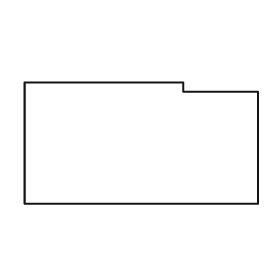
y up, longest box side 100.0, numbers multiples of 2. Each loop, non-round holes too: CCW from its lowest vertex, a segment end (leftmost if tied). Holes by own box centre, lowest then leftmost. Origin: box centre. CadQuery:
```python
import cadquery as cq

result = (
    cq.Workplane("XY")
    .moveTo(-50.0, -26.0)
    .lineTo(50.0, -26.0)
    .lineTo(50.0, 22.0)
    .lineTo(18.0, 22.0)
    .lineTo(18.0, 26.0)
    .lineTo(-50.0, 26.0)
    .close()
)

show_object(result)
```